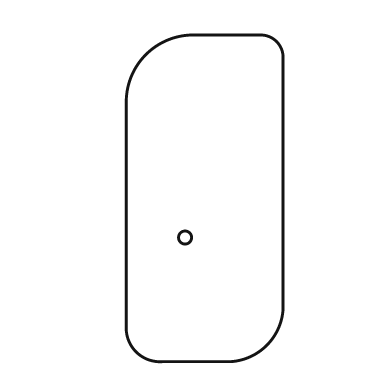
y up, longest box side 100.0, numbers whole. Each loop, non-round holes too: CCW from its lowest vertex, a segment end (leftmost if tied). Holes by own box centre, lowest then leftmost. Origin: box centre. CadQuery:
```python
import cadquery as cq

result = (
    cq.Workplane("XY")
    .moveTo(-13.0, -50.0)
    .lineTo(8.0, -50.0)
    .threePointArc((19.0, -45.0), (24.0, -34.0))
    .lineTo(24.0, 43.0)
    .threePointArc((22.0, 48.0), (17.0, 50.0))
    .lineTo(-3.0, 50.0)
    .threePointArc((-18.0, 44.0), (-24.0, 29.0))
    .lineTo(-24.0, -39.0)
    .threePointArc((-21.0, -47.0), (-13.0, -50.0))
    .close()
    .moveTo(-6.0, -12.0)
    .circle(2.0)
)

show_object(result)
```